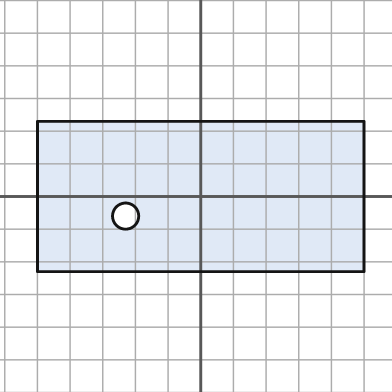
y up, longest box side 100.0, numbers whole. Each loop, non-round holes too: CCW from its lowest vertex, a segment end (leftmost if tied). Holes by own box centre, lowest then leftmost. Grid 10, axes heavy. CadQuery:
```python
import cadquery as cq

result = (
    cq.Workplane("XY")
    .moveTo(-50.0, -23.0)
    .lineTo(50.0, -23.0)
    .lineTo(50.0, 23.0)
    .lineTo(-50.0, 23.0)
    .close()
    .moveTo(-23.0, -6.0)
    .circle(4.0)
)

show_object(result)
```